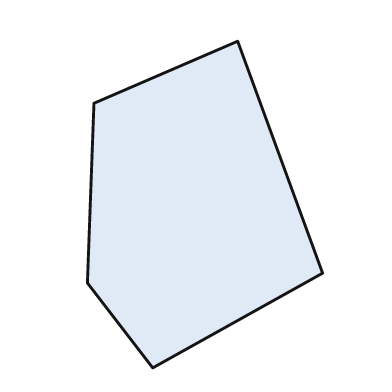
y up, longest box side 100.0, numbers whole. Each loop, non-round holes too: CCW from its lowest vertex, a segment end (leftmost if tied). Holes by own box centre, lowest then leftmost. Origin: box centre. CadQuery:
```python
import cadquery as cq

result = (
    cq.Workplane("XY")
    .moveTo(-16.0, -50.0)
    .lineTo(36.0, -21.0)
    .lineTo(10.0, 50.0)
    .lineTo(-34.0, 31.0)
    .lineTo(-36.0, -24.0)
    .close()
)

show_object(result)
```